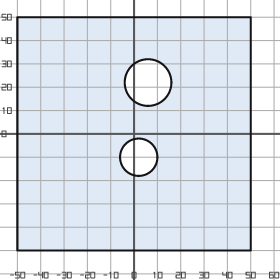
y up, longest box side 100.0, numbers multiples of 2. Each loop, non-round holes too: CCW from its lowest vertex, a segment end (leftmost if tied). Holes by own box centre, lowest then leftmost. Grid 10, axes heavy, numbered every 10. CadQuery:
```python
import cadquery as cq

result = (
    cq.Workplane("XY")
    .moveTo(-50.0, -50.0)
    .lineTo(50.0, -50.0)
    .lineTo(50.0, 50.0)
    .lineTo(-50.0, 50.0)
    .close()
    .moveTo(2.0, -10.0)
    .circle(8.0)
    .moveTo(6.0, 22.0)
    .circle(10.0)
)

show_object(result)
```